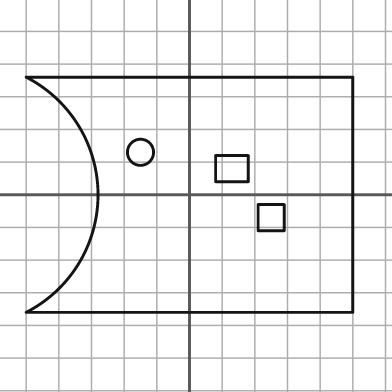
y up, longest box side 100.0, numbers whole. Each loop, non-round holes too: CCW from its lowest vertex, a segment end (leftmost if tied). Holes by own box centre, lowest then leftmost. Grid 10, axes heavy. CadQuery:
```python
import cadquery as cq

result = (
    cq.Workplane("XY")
    .moveTo(-50.0, -36.0)
    .lineTo(50.0, -36.0)
    .lineTo(50.0, 36.0)
    .lineTo(-50.0, 36.0)
    .threePointArc((-28.0, 0.0), (-50.0, -36.0))
    .close()
    .moveTo(21.0, -11.0)
    .lineTo(29.0, -11.0)
    .lineTo(29.0, -3.0)
    .lineTo(21.0, -3.0)
    .close()
    .moveTo(8.0, 4.0)
    .lineTo(18.0, 4.0)
    .lineTo(18.0, 12.0)
    .lineTo(8.0, 12.0)
    .close()
    .moveTo(-15.0, 13.0)
    .circle(4.0)
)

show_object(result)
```